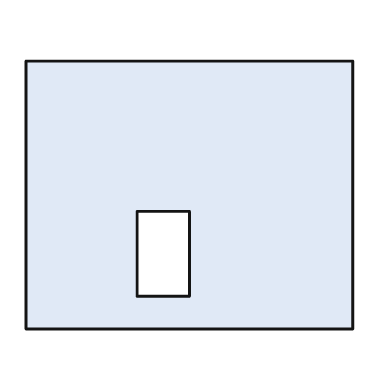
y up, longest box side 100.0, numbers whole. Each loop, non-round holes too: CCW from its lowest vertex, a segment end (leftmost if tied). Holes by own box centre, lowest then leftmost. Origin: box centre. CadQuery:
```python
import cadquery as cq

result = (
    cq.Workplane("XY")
    .moveTo(-50.0, -41.0)
    .lineTo(50.0, -41.0)
    .lineTo(50.0, 41.0)
    .lineTo(-50.0, 41.0)
    .close()
    .moveTo(-16.0, -31.0)
    .lineTo(0.0, -31.0)
    .lineTo(0.0, -5.0)
    .lineTo(-16.0, -5.0)
    .close()
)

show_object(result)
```